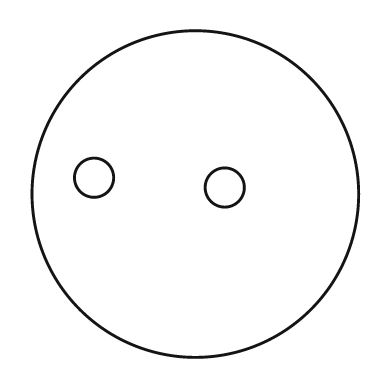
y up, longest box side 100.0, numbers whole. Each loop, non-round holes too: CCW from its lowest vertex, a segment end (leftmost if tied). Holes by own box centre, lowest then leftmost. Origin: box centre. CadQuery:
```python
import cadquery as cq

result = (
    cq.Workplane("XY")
    .moveTo(0.0, 0.0)
    .circle(50.0)
    .moveTo(9.0, 2.0)
    .circle(6.0)
    .moveTo(-31.0, 5.0)
    .circle(6.0)
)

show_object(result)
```